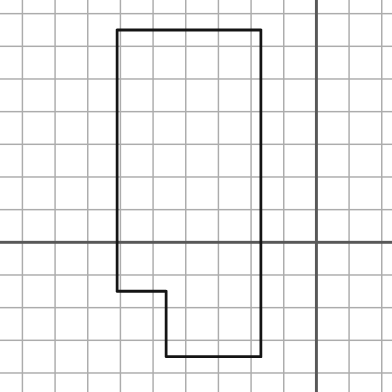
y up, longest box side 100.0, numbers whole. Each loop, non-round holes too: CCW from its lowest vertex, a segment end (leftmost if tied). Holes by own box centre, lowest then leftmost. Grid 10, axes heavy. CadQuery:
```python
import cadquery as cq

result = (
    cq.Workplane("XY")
    .moveTo(-46.0, -35.0)
    .lineTo(-17.0, -35.0)
    .lineTo(-17.0, 65.0)
    .lineTo(-61.0, 65.0)
    .lineTo(-61.0, -15.0)
    .lineTo(-46.0, -15.0)
    .close()
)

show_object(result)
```